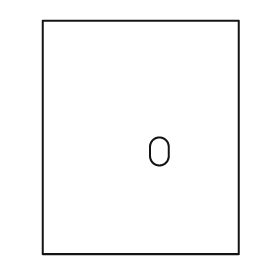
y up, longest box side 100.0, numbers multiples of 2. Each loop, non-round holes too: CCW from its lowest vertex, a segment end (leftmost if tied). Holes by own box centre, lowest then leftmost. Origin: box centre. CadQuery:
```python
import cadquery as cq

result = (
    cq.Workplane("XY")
    .moveTo(-42.0, -50.0)
    .lineTo(42.0, -50.0)
    .lineTo(42.0, 50.0)
    .lineTo(-42.0, 50.0)
    .close()
    .moveTo(4.0, -8.0)
    .threePointArc((8.0, -12.0), (12.0, -8.0))
    .lineTo(12.0, -4.0)
    .threePointArc((8.0, 0.0), (4.0, -4.0))
    .close()
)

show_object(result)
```